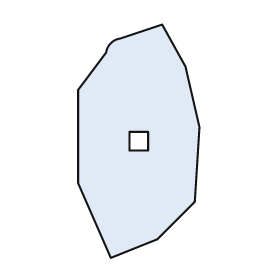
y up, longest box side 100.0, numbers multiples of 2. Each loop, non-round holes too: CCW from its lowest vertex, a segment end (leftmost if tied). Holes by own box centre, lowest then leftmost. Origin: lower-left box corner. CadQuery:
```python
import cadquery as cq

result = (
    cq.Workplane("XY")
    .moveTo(14.0, 0.0)
    .lineTo(34.0, 8.0)
    .lineTo(50.0, 24.0)
    .lineTo(52.0, 56.0)
    .lineTo(46.0, 82.0)
    .lineTo(36.0, 100.0)
    .lineTo(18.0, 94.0)
    .threePointArc((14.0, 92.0), (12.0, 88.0))
    .lineTo(0.0, 72.0)
    .lineTo(0.0, 32.0)
    .close()
    .moveTo(22.0, 46.0)
    .lineTo(30.0, 46.0)
    .lineTo(30.0, 54.0)
    .lineTo(22.0, 54.0)
    .close()
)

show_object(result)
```